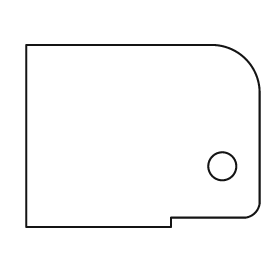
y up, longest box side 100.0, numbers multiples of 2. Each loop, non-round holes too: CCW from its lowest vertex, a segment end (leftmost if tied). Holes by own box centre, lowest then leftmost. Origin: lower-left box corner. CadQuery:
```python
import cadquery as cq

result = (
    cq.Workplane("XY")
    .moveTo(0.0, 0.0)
    .lineTo(62.0, 0.0)
    .lineTo(62.0, 4.0)
    .lineTo(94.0, 4.0)
    .threePointArc((98.0, 6.0), (100.0, 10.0))
    .lineTo(100.0, 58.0)
    .threePointArc((94.0, 72.0), (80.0, 78.0))
    .lineTo(0.0, 78.0)
    .close()
    .moveTo(84.0, 26.0)
    .circle(6.0)
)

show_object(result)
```